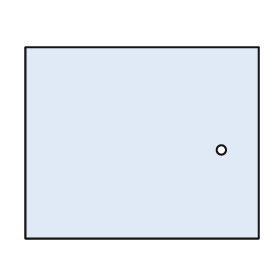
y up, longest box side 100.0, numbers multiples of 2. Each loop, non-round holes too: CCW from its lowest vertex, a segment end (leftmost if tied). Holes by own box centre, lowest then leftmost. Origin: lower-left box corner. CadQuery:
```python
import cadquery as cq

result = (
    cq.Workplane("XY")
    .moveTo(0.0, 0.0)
    .lineTo(100.0, 0.0)
    .lineTo(100.0, 82.0)
    .lineTo(0.0, 82.0)
    .close()
    .moveTo(84.0, 38.0)
    .circle(2.0)
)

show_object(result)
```